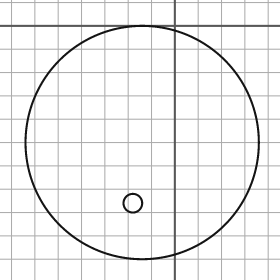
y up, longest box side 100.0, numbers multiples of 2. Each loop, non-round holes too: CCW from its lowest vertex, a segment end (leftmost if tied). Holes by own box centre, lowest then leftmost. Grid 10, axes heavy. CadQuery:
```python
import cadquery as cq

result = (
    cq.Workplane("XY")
    .moveTo(-14.0, -50.0)
    .circle(50.0)
    .moveTo(-18.0, -76.0)
    .circle(4.0)
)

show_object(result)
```